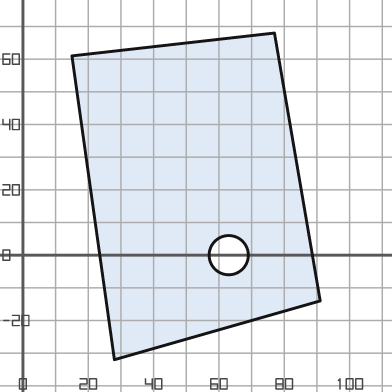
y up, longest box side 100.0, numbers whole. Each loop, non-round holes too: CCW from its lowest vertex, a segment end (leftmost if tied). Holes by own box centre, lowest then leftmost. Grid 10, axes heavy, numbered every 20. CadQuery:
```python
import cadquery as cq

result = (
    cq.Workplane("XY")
    .moveTo(28.0, -32.0)
    .lineTo(91.0, -14.0)
    .lineTo(77.0, 68.0)
    .lineTo(15.0, 61.0)
    .close()
    .moveTo(63.0, 0.0)
    .circle(6.0)
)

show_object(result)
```